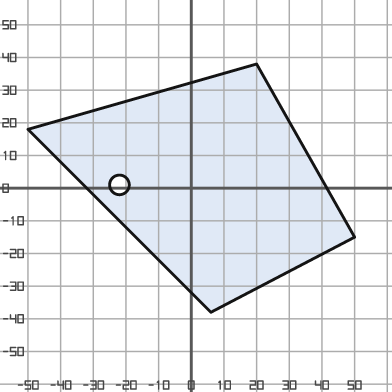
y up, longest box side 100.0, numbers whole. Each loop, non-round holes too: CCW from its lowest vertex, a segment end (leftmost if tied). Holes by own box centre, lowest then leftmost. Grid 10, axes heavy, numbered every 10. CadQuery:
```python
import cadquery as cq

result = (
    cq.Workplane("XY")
    .moveTo(6.0, -38.0)
    .lineTo(50.0, -15.0)
    .lineTo(20.0, 38.0)
    .lineTo(-50.0, 18.0)
    .close()
    .moveTo(-22.0, 1.0)
    .circle(3.0)
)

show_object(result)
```